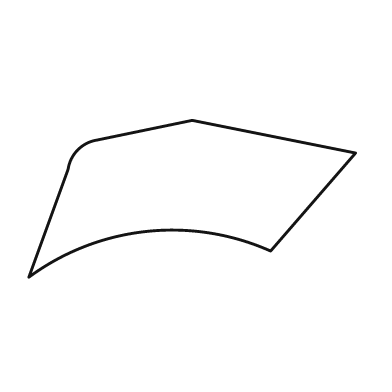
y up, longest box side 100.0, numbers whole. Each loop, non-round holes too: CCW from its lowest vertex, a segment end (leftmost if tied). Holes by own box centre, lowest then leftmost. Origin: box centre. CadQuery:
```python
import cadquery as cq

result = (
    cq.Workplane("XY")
    .moveTo(-50.0, -24.0)
    .threePointArc((-14.0, -10.0), (24.0, -16.0))
    .lineTo(50.0, 14.0)
    .lineTo(0.0, 24.0)
    .lineTo(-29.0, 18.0)
    .threePointArc((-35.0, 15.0), (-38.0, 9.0))
    .close()
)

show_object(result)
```